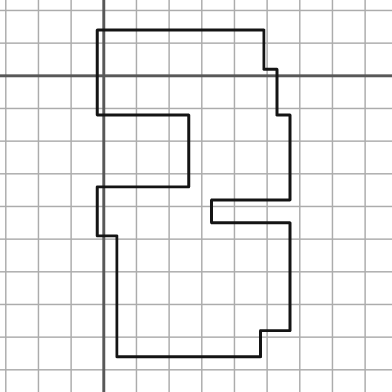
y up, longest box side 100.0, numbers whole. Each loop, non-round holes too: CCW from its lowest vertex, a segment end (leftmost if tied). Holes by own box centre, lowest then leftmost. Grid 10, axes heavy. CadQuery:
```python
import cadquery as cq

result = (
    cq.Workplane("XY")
    .moveTo(4.0, -86.0)
    .lineTo(48.0, -86.0)
    .lineTo(48.0, -78.0)
    .lineTo(57.0, -78.0)
    .lineTo(57.0, -45.0)
    .lineTo(33.0, -45.0)
    .lineTo(33.0, -38.0)
    .lineTo(57.0, -38.0)
    .lineTo(57.0, -12.0)
    .lineTo(53.0, -12.0)
    .lineTo(53.0, 2.0)
    .lineTo(49.0, 2.0)
    .lineTo(49.0, 14.0)
    .lineTo(-2.0, 14.0)
    .lineTo(-2.0, -12.0)
    .lineTo(26.0, -12.0)
    .lineTo(26.0, -34.0)
    .lineTo(-2.0, -34.0)
    .lineTo(-2.0, -49.0)
    .lineTo(4.0, -49.0)
    .close()
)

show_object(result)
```